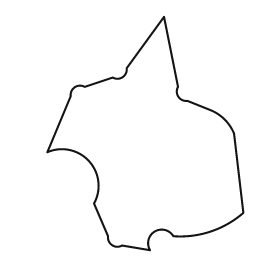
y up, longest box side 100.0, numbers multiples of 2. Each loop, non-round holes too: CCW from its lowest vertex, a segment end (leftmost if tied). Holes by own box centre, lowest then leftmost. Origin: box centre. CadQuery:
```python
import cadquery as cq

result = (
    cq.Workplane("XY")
    .moveTo(2.0, -50.0)
    .threePointArc((4.0, -42.0), (12.0, -44.0))
    .threePointArc((28.0, -42.0), (42.0, -34.0))
    .lineTo(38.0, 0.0)
    .threePointArc((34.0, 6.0), (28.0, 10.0))
    .lineTo(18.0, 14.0)
    .threePointArc((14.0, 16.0), (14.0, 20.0))
    .lineTo(8.0, 50.0)
    .lineTo(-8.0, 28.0)
    .threePointArc((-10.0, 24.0), (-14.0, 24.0))
    .lineTo(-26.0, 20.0)
    .threePointArc((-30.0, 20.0), (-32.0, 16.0))
    .lineTo(-42.0, -8.0)
    .threePointArc((-24.0, -12.0), (-22.0, -30.0))
    .lineTo(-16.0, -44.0)
    .threePointArc((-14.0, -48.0), (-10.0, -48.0))
    .close()
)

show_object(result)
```